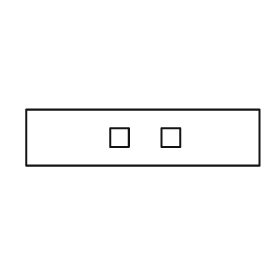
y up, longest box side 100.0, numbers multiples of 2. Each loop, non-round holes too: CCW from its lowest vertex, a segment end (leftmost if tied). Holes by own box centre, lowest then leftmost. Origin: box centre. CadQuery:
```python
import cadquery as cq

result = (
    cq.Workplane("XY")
    .moveTo(-50.0, -12.0)
    .lineTo(50.0, -12.0)
    .lineTo(50.0, 12.0)
    .lineTo(-50.0, 12.0)
    .close()
    .moveTo(-14.0, -4.0)
    .lineTo(-6.0, -4.0)
    .lineTo(-6.0, 4.0)
    .lineTo(-14.0, 4.0)
    .close()
    .moveTo(8.0, -4.0)
    .lineTo(16.0, -4.0)
    .lineTo(16.0, 4.0)
    .lineTo(8.0, 4.0)
    .close()
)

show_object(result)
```